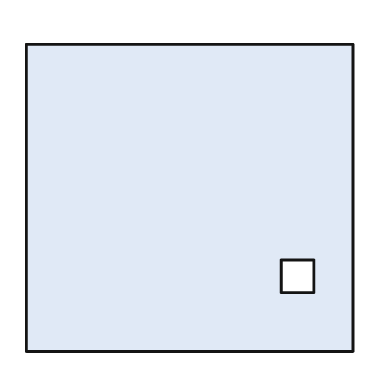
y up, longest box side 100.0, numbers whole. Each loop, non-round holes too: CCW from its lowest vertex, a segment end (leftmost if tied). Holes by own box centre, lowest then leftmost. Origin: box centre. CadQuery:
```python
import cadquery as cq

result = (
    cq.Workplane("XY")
    .moveTo(-50.0, -47.0)
    .lineTo(50.0, -47.0)
    .lineTo(50.0, 47.0)
    .lineTo(-50.0, 47.0)
    .close()
    .moveTo(28.0, -29.0)
    .lineTo(38.0, -29.0)
    .lineTo(38.0, -19.0)
    .lineTo(28.0, -19.0)
    .close()
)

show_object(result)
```